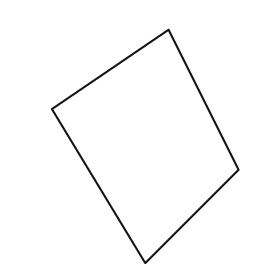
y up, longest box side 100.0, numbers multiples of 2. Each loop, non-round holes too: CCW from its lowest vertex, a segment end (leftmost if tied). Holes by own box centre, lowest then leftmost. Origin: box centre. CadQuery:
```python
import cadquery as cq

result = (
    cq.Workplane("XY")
    .moveTo(0.0, -50.0)
    .lineTo(40.0, -10.0)
    .lineTo(10.0, 50.0)
    .lineTo(-40.0, 16.0)
    .close()
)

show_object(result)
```